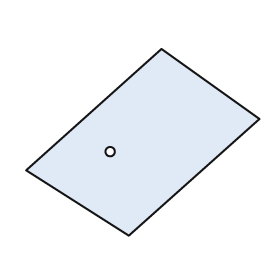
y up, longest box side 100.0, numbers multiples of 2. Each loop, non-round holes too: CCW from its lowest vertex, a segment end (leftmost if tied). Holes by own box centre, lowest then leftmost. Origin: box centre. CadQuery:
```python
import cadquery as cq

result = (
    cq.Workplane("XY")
    .moveTo(-6.0, -40.0)
    .lineTo(50.0, 10.0)
    .lineTo(8.0, 40.0)
    .lineTo(-50.0, -12.0)
    .close()
    .moveTo(-14.0, -4.0)
    .circle(2.0)
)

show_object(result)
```